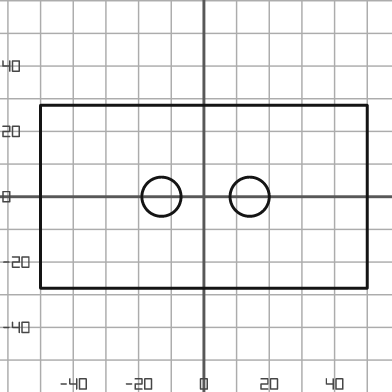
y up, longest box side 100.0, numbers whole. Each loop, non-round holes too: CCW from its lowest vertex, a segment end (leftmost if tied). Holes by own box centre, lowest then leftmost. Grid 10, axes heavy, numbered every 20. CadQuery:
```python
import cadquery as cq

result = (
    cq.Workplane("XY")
    .moveTo(-50.0, -28.0)
    .lineTo(50.0, -28.0)
    .lineTo(50.0, 28.0)
    .lineTo(-50.0, 28.0)
    .close()
    .moveTo(-13.0, 0.0)
    .circle(6.0)
    .moveTo(14.0, 0.0)
    .circle(6.0)
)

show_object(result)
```